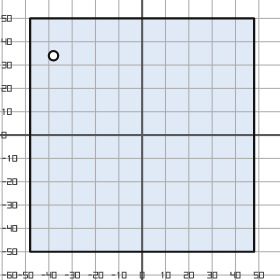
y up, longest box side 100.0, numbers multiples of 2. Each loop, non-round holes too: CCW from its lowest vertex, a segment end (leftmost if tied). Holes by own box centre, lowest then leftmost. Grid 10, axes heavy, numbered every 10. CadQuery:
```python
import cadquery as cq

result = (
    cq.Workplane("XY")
    .moveTo(-48.0, -50.0)
    .lineTo(48.0, -50.0)
    .lineTo(48.0, 50.0)
    .lineTo(-48.0, 50.0)
    .close()
    .moveTo(-38.0, 34.0)
    .circle(2.0)
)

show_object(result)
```